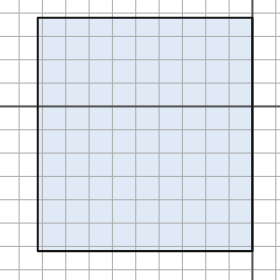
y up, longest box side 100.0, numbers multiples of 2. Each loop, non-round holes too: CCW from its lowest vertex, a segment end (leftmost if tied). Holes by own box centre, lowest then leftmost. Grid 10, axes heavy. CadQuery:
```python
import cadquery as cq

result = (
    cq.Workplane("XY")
    .moveTo(-92.0, -62.0)
    .lineTo(0.0, -62.0)
    .lineTo(0.0, 38.0)
    .lineTo(-92.0, 38.0)
    .close()
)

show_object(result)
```